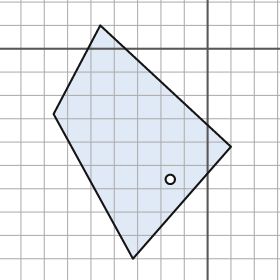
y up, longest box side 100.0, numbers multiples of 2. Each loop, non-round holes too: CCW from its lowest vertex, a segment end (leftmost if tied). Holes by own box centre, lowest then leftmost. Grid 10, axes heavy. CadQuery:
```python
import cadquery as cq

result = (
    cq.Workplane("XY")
    .moveTo(-32.0, -90.0)
    .lineTo(10.0, -42.0)
    .lineTo(-46.0, 10.0)
    .lineTo(-66.0, -28.0)
    .close()
    .moveTo(-16.0, -56.0)
    .circle(2.0)
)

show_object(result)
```